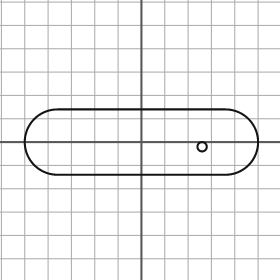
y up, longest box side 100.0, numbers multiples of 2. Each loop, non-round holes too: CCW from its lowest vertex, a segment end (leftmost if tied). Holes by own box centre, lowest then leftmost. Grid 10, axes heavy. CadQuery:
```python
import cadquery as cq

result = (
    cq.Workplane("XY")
    .moveTo(-36.0, -14.0)
    .lineTo(36.0, -14.0)
    .threePointArc((50.0, 0.0), (36.0, 14.0))
    .lineTo(-36.0, 14.0)
    .threePointArc((-50.0, 0.0), (-36.0, -14.0))
    .close()
    .moveTo(26.0, -2.0)
    .circle(2.0)
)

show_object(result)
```